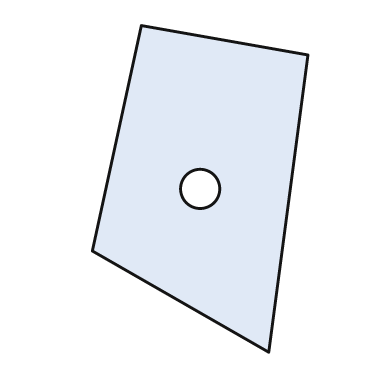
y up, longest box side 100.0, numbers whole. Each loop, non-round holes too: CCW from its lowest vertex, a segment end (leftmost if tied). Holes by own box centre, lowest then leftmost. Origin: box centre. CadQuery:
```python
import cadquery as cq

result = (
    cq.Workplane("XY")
    .moveTo(21.0, -50.0)
    .lineTo(33.0, 41.0)
    .lineTo(-18.0, 50.0)
    .lineTo(-33.0, -19.0)
    .close()
    .moveTo(0.0, 0.0)
    .circle(6.0)
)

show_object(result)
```